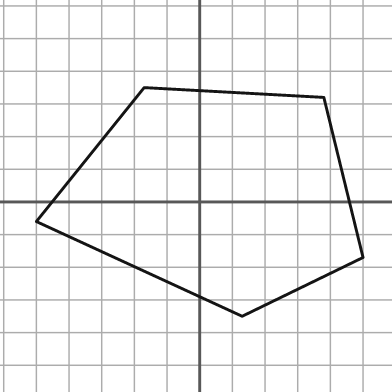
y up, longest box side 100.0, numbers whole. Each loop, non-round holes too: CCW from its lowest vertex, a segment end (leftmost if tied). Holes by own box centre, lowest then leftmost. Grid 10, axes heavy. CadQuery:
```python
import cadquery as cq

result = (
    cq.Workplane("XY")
    .moveTo(13.0, -35.0)
    .lineTo(50.0, -17.0)
    .lineTo(38.0, 32.0)
    .lineTo(-17.0, 35.0)
    .lineTo(-50.0, -6.0)
    .close()
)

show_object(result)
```